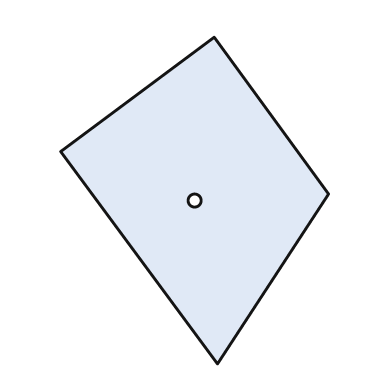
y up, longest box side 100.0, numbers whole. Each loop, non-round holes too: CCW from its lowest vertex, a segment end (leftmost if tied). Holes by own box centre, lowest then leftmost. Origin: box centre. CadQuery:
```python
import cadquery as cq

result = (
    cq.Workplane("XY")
    .moveTo(7.0, -50.0)
    .lineTo(41.0, 2.0)
    .lineTo(6.0, 50.0)
    .lineTo(-41.0, 15.0)
    .close()
    .moveTo(0.0, 0.0)
    .circle(2.0)
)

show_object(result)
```